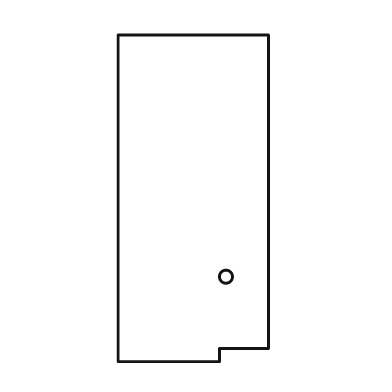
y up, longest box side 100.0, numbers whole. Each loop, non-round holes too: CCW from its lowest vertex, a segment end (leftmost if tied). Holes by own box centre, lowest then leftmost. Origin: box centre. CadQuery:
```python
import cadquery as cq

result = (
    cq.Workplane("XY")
    .moveTo(-23.0, -50.0)
    .lineTo(8.0, -50.0)
    .lineTo(8.0, -46.0)
    .lineTo(23.0, -46.0)
    .lineTo(23.0, 50.0)
    .lineTo(-23.0, 50.0)
    .close()
    .moveTo(10.0, -24.0)
    .circle(2.0)
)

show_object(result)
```